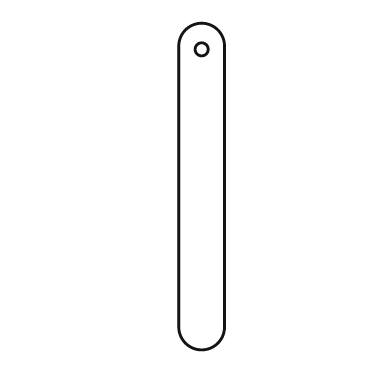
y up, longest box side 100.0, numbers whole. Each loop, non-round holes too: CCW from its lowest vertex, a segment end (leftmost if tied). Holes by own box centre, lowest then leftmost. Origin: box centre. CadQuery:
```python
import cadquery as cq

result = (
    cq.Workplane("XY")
    .moveTo(-7.0, -43.0)
    .threePointArc((0.0, -50.0), (7.0, -43.0))
    .lineTo(7.0, 43.0)
    .threePointArc((0.0, 50.0), (-7.0, 43.0))
    .close()
    .moveTo(0.0, 42.0)
    .circle(2.0)
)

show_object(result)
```